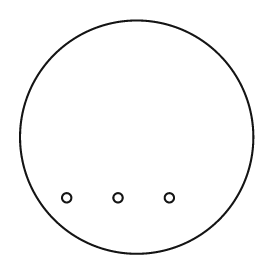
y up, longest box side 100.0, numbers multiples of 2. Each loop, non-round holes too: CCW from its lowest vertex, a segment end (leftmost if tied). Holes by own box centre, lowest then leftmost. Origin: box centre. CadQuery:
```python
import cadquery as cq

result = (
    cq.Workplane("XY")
    .moveTo(0.0, 0.0)
    .circle(50.0)
    .moveTo(-30.0, -26.0)
    .circle(2.0)
    .moveTo(-8.0, -26.0)
    .circle(2.0)
    .moveTo(14.0, -26.0)
    .circle(2.0)
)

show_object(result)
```